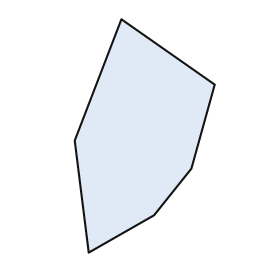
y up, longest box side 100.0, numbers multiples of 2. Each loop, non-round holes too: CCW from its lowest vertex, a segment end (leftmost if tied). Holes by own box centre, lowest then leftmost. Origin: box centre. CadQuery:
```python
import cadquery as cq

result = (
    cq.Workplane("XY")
    .moveTo(-24.0, -50.0)
    .lineTo(4.0, -34.0)
    .lineTo(20.0, -14.0)
    .lineTo(30.0, 22.0)
    .lineTo(-10.0, 50.0)
    .lineTo(-30.0, -2.0)
    .close()
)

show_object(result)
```